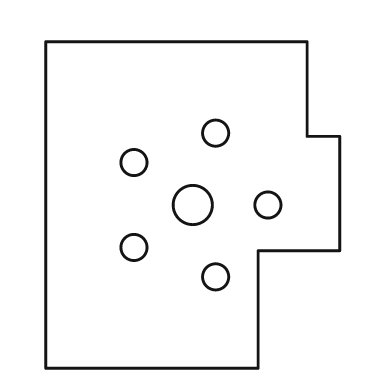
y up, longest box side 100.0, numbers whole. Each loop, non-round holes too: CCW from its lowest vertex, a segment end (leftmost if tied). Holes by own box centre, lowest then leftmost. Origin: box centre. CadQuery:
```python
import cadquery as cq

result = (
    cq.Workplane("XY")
    .moveTo(-45.0, -50.0)
    .lineTo(20.0, -50.0)
    .lineTo(20.0, -14.0)
    .lineTo(45.0, -14.0)
    .lineTo(45.0, 21.0)
    .lineTo(35.0, 21.0)
    .lineTo(35.0, 50.0)
    .lineTo(-45.0, 50.0)
    .close()
    .moveTo(7.0, -22.0)
    .circle(4.0)
    .moveTo(-18.0, -13.0)
    .circle(4.0)
    .moveTo(0.0, 0.0)
    .circle(6.0)
    .moveTo(23.0, 0.0)
    .circle(4.0)
    .moveTo(-18.0, 13.0)
    .circle(4.0)
    .moveTo(7.0, 22.0)
    .circle(4.0)
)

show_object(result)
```